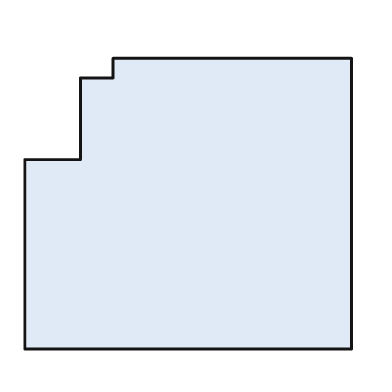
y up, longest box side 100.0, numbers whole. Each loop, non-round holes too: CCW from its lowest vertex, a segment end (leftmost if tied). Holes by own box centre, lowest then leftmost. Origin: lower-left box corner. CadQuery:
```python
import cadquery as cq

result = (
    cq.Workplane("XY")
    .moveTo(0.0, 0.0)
    .lineTo(100.0, 0.0)
    .lineTo(100.0, 89.0)
    .lineTo(27.0, 89.0)
    .lineTo(27.0, 83.0)
    .lineTo(17.0, 83.0)
    .lineTo(17.0, 58.0)
    .lineTo(0.0, 58.0)
    .close()
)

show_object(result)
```